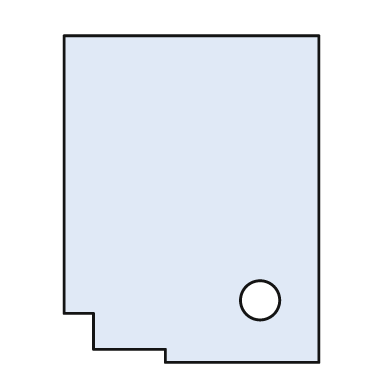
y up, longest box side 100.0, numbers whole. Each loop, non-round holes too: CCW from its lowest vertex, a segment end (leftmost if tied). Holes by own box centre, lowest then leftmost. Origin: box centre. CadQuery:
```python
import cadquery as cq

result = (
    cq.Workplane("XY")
    .moveTo(-8.0, -50.0)
    .lineTo(39.0, -50.0)
    .lineTo(39.0, 50.0)
    .lineTo(-39.0, 50.0)
    .lineTo(-39.0, -35.0)
    .lineTo(-30.0, -35.0)
    .lineTo(-30.0, -46.0)
    .lineTo(-8.0, -46.0)
    .close()
    .moveTo(21.0, -31.0)
    .circle(6.0)
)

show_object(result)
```